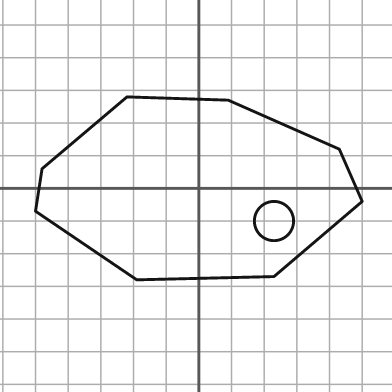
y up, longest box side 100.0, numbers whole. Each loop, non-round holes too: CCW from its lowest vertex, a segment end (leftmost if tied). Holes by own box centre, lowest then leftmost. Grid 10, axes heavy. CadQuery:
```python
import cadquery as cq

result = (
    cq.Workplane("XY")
    .moveTo(-19.0, -28.0)
    .lineTo(23.0, -27.0)
    .lineTo(50.0, -4.0)
    .lineTo(43.0, 12.0)
    .lineTo(9.0, 27.0)
    .lineTo(-22.0, 28.0)
    .lineTo(-48.0, 6.0)
    .lineTo(-50.0, -7.0)
    .close()
    .moveTo(23.0, -10.0)
    .circle(6.0)
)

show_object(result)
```